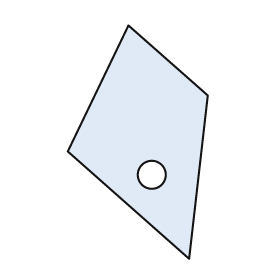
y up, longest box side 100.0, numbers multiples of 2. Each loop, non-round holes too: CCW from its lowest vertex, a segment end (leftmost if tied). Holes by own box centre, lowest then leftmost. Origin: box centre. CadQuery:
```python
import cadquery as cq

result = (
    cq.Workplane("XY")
    .moveTo(22.0, -50.0)
    .lineTo(30.0, 20.0)
    .lineTo(-4.0, 50.0)
    .lineTo(-30.0, -4.0)
    .close()
    .moveTo(6.0, -14.0)
    .circle(6.0)
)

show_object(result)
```